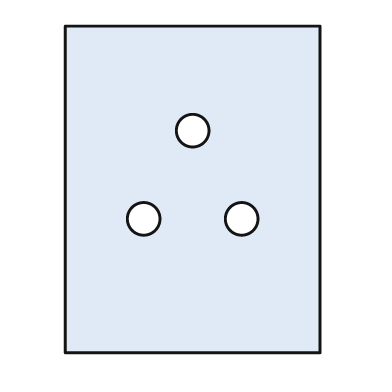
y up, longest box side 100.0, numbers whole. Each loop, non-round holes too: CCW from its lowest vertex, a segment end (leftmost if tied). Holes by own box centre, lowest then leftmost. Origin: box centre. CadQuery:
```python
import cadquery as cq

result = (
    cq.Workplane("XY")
    .moveTo(-39.0, -50.0)
    .lineTo(39.0, -50.0)
    .lineTo(39.0, 50.0)
    .lineTo(-39.0, 50.0)
    .close()
    .moveTo(-15.0, -9.0)
    .circle(5.0)
    .moveTo(15.0, -9.0)
    .circle(5.0)
    .moveTo(0.0, 18.0)
    .circle(5.0)
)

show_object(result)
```